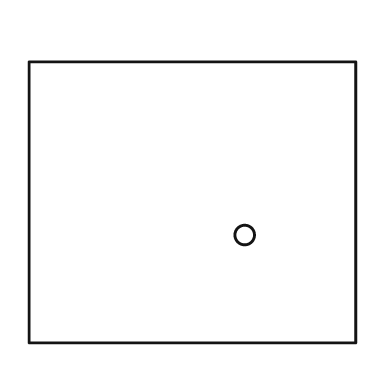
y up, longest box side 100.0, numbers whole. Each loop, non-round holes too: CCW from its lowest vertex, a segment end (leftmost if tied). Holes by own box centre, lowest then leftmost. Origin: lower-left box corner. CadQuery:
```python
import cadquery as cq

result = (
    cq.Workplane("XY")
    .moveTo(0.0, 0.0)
    .lineTo(100.0, 0.0)
    .lineTo(100.0, 86.0)
    .lineTo(0.0, 86.0)
    .close()
    .moveTo(66.0, 33.0)
    .circle(3.0)
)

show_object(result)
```